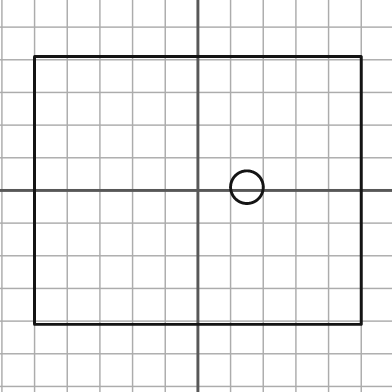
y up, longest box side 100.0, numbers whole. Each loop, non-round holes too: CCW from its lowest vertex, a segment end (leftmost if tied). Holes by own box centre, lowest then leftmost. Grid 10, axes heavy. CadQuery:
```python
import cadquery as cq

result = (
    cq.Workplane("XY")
    .moveTo(-50.0, -41.0)
    .lineTo(50.0, -41.0)
    .lineTo(50.0, 41.0)
    .lineTo(-50.0, 41.0)
    .close()
    .moveTo(15.0, 1.0)
    .circle(5.0)
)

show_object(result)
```